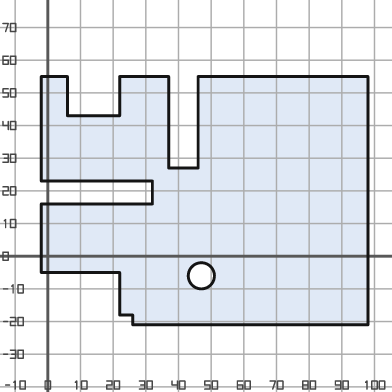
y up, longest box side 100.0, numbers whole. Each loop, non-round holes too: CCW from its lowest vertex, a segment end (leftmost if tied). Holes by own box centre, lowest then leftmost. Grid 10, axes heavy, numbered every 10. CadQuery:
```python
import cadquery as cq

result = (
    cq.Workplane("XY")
    .moveTo(26.0, -21.0)
    .lineTo(98.0, -21.0)
    .lineTo(98.0, 55.0)
    .lineTo(46.0, 55.0)
    .lineTo(46.0, 27.0)
    .lineTo(37.0, 27.0)
    .lineTo(37.0, 55.0)
    .lineTo(22.0, 55.0)
    .lineTo(22.0, 43.0)
    .lineTo(6.0, 43.0)
    .lineTo(6.0, 55.0)
    .lineTo(-2.0, 55.0)
    .lineTo(-2.0, 23.0)
    .lineTo(32.0, 23.0)
    .lineTo(32.0, 16.0)
    .lineTo(-2.0, 16.0)
    .lineTo(-2.0, -5.0)
    .lineTo(22.0, -5.0)
    .lineTo(22.0, -18.0)
    .lineTo(26.0, -18.0)
    .close()
    .moveTo(47.0, -6.0)
    .circle(4.0)
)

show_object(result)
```